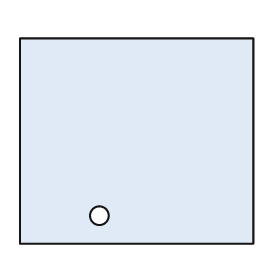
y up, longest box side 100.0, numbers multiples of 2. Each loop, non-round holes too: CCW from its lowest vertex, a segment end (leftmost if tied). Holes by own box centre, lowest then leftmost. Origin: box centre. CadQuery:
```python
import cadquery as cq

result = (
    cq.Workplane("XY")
    .moveTo(-50.0, -44.0)
    .lineTo(50.0, -44.0)
    .lineTo(50.0, 44.0)
    .lineTo(-50.0, 44.0)
    .close()
    .moveTo(-16.0, -32.0)
    .circle(4.0)
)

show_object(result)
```